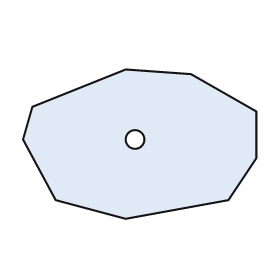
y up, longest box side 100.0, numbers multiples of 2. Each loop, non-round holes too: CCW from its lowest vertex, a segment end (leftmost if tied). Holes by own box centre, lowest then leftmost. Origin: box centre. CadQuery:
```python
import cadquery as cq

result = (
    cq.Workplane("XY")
    .moveTo(-6.0, -32.0)
    .lineTo(38.0, -24.0)
    .lineTo(50.0, -6.0)
    .lineTo(50.0, 14.0)
    .lineTo(22.0, 30.0)
    .lineTo(-6.0, 32.0)
    .lineTo(-46.0, 16.0)
    .lineTo(-50.0, 2.0)
    .lineTo(-36.0, -24.0)
    .close()
    .moveTo(-2.0, 2.0)
    .circle(4.0)
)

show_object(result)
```